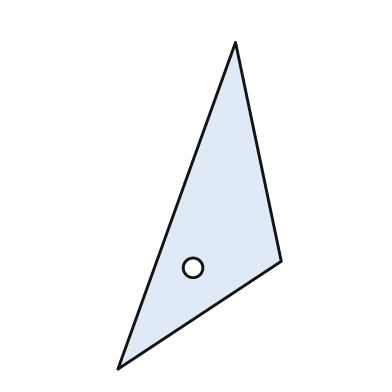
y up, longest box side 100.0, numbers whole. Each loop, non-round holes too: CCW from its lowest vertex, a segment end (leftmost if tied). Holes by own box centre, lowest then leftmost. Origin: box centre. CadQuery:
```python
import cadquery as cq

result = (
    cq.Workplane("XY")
    .moveTo(-25.0, -50.0)
    .lineTo(25.0, -17.0)
    .lineTo(11.0, 50.0)
    .close()
    .moveTo(-2.0, -19.0)
    .circle(3.0)
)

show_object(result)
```